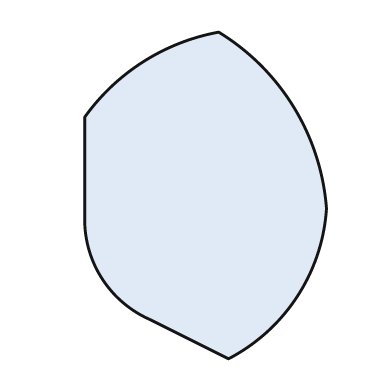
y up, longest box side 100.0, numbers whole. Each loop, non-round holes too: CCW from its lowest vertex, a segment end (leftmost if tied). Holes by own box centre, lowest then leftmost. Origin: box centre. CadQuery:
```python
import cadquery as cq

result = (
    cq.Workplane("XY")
    .moveTo(7.0, -50.0)
    .threePointArc((28.0, -31.0), (37.0, -4.0))
    .threePointArc((27.0, 27.0), (4.0, 50.0))
    .threePointArc((-19.0, 41.0), (-37.0, 24.0))
    .lineTo(-37.0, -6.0)
    .threePointArc((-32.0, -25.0), (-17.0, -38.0))
    .close()
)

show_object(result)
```